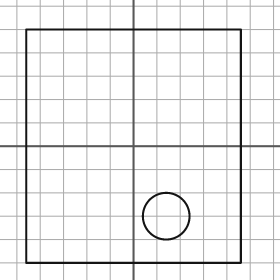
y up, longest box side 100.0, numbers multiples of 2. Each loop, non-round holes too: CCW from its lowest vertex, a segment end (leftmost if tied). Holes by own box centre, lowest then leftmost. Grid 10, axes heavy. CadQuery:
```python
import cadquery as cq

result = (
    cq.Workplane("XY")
    .moveTo(-46.0, -50.0)
    .lineTo(46.0, -50.0)
    .lineTo(46.0, 50.0)
    .lineTo(-46.0, 50.0)
    .close()
    .moveTo(14.0, -30.0)
    .circle(10.0)
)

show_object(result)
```